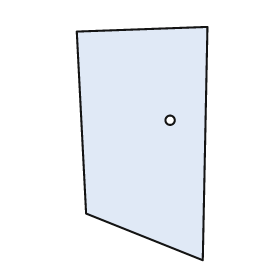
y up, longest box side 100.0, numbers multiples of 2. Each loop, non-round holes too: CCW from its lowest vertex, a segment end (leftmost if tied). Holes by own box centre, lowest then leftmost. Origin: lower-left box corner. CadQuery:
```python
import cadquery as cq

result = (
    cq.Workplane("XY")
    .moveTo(54.0, 0.0)
    .lineTo(56.0, 100.0)
    .lineTo(0.0, 98.0)
    .lineTo(4.0, 20.0)
    .close()
    .moveTo(40.0, 60.0)
    .circle(2.0)
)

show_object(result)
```